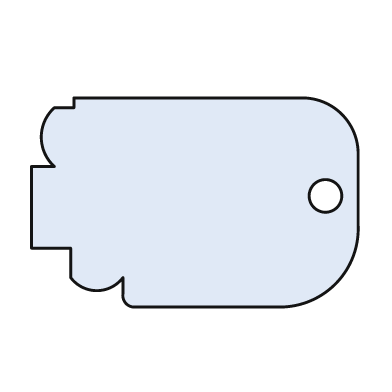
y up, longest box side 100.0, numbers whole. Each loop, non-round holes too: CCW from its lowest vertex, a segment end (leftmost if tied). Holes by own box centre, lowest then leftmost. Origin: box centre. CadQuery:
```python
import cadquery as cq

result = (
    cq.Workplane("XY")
    .moveTo(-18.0, -32.0)
    .lineTo(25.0, -32.0)
    .threePointArc((43.0, -25.0), (50.0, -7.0))
    .lineTo(50.0, 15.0)
    .threePointArc((45.0, 27.0), (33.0, 32.0))
    .lineTo(-37.0, 32.0)
    .lineTo(-37.0, 29.0)
    .lineTo(-43.0, 29.0)
    .threePointArc((-47.0, 20.0), (-43.0, 11.0))
    .lineTo(-50.0, 11.0)
    .lineTo(-50.0, -14.0)
    .lineTo(-38.0, -14.0)
    .lineTo(-38.0, -23.0)
    .threePointArc((-30.0, -27.0), (-22.0, -23.0))
    .lineTo(-22.0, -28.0)
    .threePointArc((-21.0, -31.0), (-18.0, -32.0))
    .close()
    .moveTo(40.0, 2.0)
    .circle(5.0)
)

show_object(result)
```